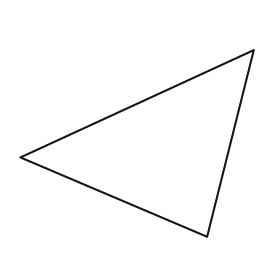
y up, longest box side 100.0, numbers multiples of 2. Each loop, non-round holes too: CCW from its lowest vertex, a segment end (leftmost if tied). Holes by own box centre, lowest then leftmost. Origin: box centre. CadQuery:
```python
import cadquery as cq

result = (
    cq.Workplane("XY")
    .moveTo(30.0, -40.0)
    .lineTo(50.0, 40.0)
    .lineTo(-50.0, -6.0)
    .close()
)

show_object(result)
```